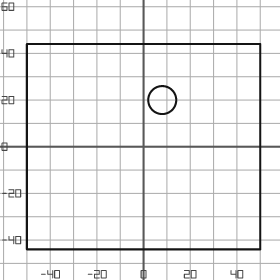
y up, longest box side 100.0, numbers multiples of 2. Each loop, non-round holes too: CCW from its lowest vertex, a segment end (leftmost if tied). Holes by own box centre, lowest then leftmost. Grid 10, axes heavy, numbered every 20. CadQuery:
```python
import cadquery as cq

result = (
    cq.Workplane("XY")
    .moveTo(-50.0, -44.0)
    .lineTo(50.0, -44.0)
    .lineTo(50.0, 44.0)
    .lineTo(-50.0, 44.0)
    .close()
    .moveTo(8.0, 20.0)
    .circle(6.0)
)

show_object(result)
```